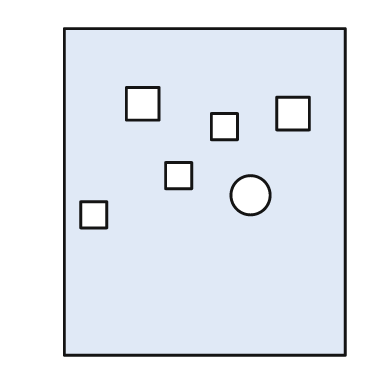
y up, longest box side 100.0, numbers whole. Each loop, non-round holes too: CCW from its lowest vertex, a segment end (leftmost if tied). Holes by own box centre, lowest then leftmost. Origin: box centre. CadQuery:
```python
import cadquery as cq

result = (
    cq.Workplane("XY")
    .moveTo(-43.0, -50.0)
    .lineTo(43.0, -50.0)
    .lineTo(43.0, 50.0)
    .lineTo(-43.0, 50.0)
    .close()
    .moveTo(-38.0, -11.0)
    .lineTo(-30.0, -11.0)
    .lineTo(-30.0, -3.0)
    .lineTo(-38.0, -3.0)
    .close()
    .moveTo(14.0, -1.0)
    .circle(6.0)
    .moveTo(-12.0, 1.0)
    .lineTo(-4.0, 1.0)
    .lineTo(-4.0, 9.0)
    .lineTo(-12.0, 9.0)
    .close()
    .moveTo(2.0, 16.0)
    .lineTo(10.0, 16.0)
    .lineTo(10.0, 24.0)
    .lineTo(2.0, 24.0)
    .close()
    .moveTo(22.0, 19.0)
    .lineTo(32.0, 19.0)
    .lineTo(32.0, 29.0)
    .lineTo(22.0, 29.0)
    .close()
    .moveTo(-24.0, 22.0)
    .lineTo(-14.0, 22.0)
    .lineTo(-14.0, 32.0)
    .lineTo(-24.0, 32.0)
    .close()
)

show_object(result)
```